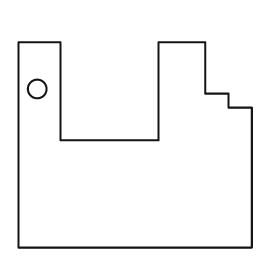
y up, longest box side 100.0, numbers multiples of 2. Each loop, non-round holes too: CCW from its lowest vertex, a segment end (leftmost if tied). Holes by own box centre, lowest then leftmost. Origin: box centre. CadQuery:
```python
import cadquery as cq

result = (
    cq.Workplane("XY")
    .moveTo(-50.0, -44.0)
    .lineTo(50.0, -44.0)
    .lineTo(50.0, 16.0)
    .lineTo(40.0, 16.0)
    .lineTo(40.0, 22.0)
    .lineTo(30.0, 22.0)
    .lineTo(30.0, 44.0)
    .lineTo(10.0, 44.0)
    .lineTo(10.0, 2.0)
    .lineTo(-32.0, 2.0)
    .lineTo(-32.0, 44.0)
    .lineTo(-50.0, 44.0)
    .close()
    .moveTo(-42.0, 24.0)
    .circle(4.0)
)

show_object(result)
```